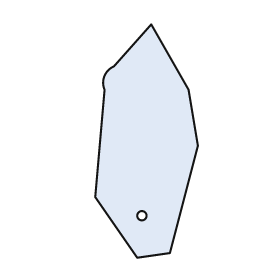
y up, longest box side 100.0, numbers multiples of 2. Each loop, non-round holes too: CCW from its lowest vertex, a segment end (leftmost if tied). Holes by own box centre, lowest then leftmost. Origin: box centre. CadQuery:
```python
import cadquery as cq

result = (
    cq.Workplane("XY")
    .moveTo(-4.0, -50.0)
    .lineTo(10.0, -48.0)
    .lineTo(22.0, -2.0)
    .lineTo(18.0, 22.0)
    .lineTo(2.0, 50.0)
    .lineTo(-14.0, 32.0)
    .threePointArc((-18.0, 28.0), (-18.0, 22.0))
    .lineTo(-22.0, -24.0)
    .close()
    .moveTo(-2.0, -32.0)
    .circle(2.0)
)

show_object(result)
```